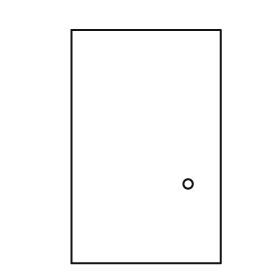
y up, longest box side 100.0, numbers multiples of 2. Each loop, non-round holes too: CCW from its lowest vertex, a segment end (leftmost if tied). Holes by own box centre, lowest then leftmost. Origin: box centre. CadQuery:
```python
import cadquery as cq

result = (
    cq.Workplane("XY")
    .moveTo(-32.0, -50.0)
    .lineTo(32.0, -50.0)
    .lineTo(32.0, 50.0)
    .lineTo(-32.0, 50.0)
    .close()
    .moveTo(18.0, -16.0)
    .circle(2.0)
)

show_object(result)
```